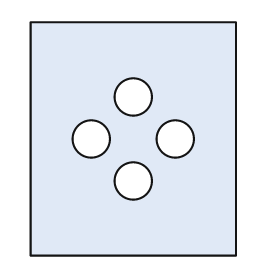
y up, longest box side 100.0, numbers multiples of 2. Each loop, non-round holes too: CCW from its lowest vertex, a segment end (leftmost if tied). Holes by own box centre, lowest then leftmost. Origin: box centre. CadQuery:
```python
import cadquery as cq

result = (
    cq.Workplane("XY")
    .moveTo(-44.0, -50.0)
    .lineTo(44.0, -50.0)
    .lineTo(44.0, 50.0)
    .lineTo(-44.0, 50.0)
    .close()
    .moveTo(0.0, -18.0)
    .circle(8.0)
    .moveTo(-18.0, 0.0)
    .circle(8.0)
    .moveTo(18.0, 0.0)
    .circle(8.0)
    .moveTo(0.0, 18.0)
    .circle(8.0)
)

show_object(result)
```